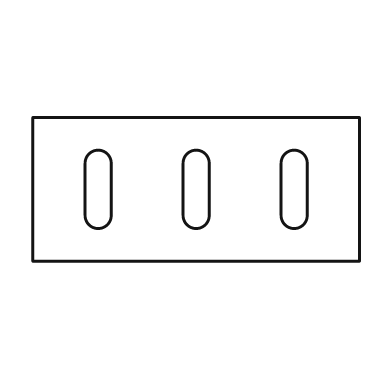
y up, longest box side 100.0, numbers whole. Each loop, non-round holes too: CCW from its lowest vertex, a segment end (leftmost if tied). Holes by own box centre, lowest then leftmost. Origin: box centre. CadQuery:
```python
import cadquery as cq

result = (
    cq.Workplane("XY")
    .moveTo(-50.0, -22.0)
    .lineTo(50.0, -22.0)
    .lineTo(50.0, 22.0)
    .lineTo(-50.0, 22.0)
    .close()
    .moveTo(-34.0, -8.0)
    .threePointArc((-30.0, -12.0), (-26.0, -8.0))
    .lineTo(-26.0, 8.0)
    .threePointArc((-30.0, 12.0), (-34.0, 8.0))
    .close()
    .moveTo(-4.0, -8.0)
    .threePointArc((0.0, -12.0), (4.0, -8.0))
    .lineTo(4.0, 8.0)
    .threePointArc((0.0, 12.0), (-4.0, 8.0))
    .close()
    .moveTo(26.0, -8.0)
    .threePointArc((30.0, -12.0), (34.0, -8.0))
    .lineTo(34.0, 8.0)
    .threePointArc((30.0, 12.0), (26.0, 8.0))
    .close()
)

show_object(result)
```